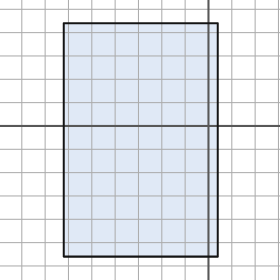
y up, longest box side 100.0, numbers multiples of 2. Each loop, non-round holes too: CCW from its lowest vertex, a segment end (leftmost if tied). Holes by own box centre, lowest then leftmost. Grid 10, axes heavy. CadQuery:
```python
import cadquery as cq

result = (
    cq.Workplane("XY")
    .moveTo(-62.0, -56.0)
    .lineTo(4.0, -56.0)
    .lineTo(4.0, 44.0)
    .lineTo(-62.0, 44.0)
    .close()
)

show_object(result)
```